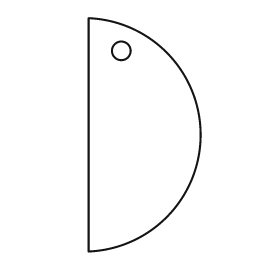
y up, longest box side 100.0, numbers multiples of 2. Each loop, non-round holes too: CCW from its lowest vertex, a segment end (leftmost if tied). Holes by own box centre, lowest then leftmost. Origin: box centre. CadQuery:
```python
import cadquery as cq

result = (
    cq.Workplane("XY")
    .moveTo(-24.0, -50.0)
    .threePointArc((24.0, 0.0), (-24.0, 50.0))
    .close()
    .moveTo(-10.0, 36.0)
    .circle(4.0)
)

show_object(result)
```